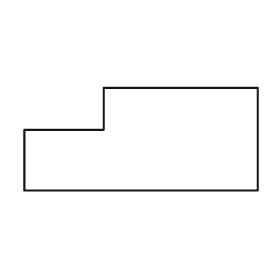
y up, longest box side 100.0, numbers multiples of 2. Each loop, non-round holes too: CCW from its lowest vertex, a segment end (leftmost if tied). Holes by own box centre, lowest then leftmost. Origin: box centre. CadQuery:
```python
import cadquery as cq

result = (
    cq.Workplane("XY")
    .moveTo(-50.0, -22.0)
    .lineTo(50.0, -22.0)
    .lineTo(50.0, 22.0)
    .lineTo(-16.0, 22.0)
    .lineTo(-16.0, 4.0)
    .lineTo(-50.0, 4.0)
    .close()
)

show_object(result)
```